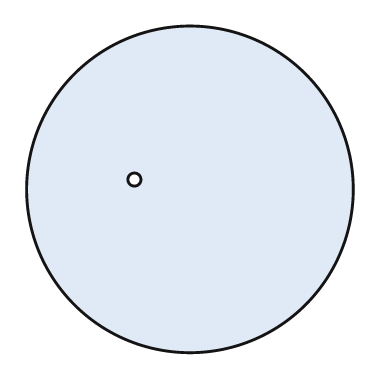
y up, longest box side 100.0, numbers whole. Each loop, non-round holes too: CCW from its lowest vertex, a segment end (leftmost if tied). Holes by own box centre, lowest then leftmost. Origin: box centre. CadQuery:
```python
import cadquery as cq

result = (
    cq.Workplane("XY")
    .moveTo(0.0, 0.0)
    .circle(50.0)
    .moveTo(-17.0, 3.0)
    .circle(2.0)
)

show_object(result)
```